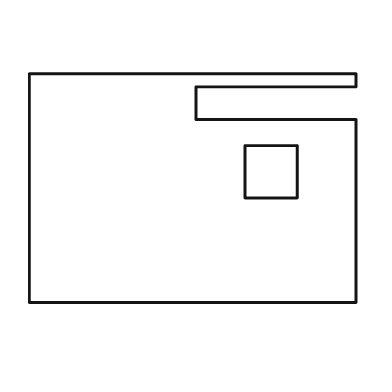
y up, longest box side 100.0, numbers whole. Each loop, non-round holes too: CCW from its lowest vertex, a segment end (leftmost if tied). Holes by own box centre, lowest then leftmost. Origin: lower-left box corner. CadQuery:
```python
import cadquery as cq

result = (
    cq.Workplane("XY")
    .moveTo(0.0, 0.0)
    .lineTo(100.0, 0.0)
    .lineTo(100.0, 56.0)
    .lineTo(51.0, 56.0)
    .lineTo(51.0, 66.0)
    .lineTo(100.0, 66.0)
    .lineTo(100.0, 70.0)
    .lineTo(0.0, 70.0)
    .close()
    .moveTo(66.0, 32.0)
    .lineTo(82.0, 32.0)
    .lineTo(82.0, 48.0)
    .lineTo(66.0, 48.0)
    .close()
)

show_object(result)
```